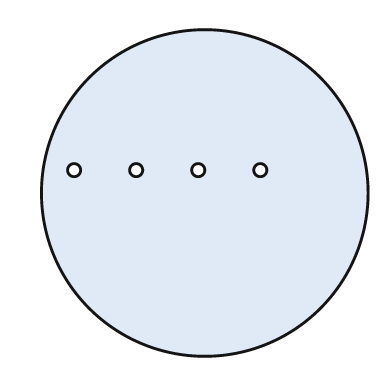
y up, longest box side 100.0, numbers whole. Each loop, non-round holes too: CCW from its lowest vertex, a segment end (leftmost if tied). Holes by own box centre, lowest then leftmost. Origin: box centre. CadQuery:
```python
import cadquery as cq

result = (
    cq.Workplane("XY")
    .moveTo(0.0, 0.0)
    .circle(50.0)
    .moveTo(-40.0, 7.0)
    .circle(2.0)
    .moveTo(-21.0, 7.0)
    .circle(2.0)
    .moveTo(-2.0, 7.0)
    .circle(2.0)
    .moveTo(17.0, 7.0)
    .circle(2.0)
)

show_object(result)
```